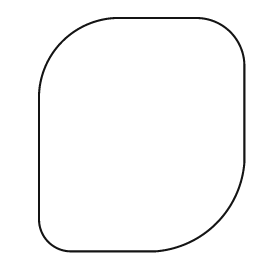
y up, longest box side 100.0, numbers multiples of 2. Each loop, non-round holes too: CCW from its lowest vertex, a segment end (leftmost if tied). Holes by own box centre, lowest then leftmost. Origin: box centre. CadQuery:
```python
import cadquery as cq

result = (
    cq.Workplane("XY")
    .moveTo(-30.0, -50.0)
    .lineTo(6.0, -50.0)
    .threePointArc((32.0, -38.0), (44.0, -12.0))
    .lineTo(44.0, 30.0)
    .threePointArc((38.0, 44.0), (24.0, 50.0))
    .lineTo(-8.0, 50.0)
    .threePointArc((-34.0, 40.0), (-44.0, 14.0))
    .lineTo(-44.0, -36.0)
    .threePointArc((-40.0, -46.0), (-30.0, -50.0))
    .close()
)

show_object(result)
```